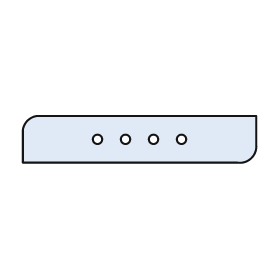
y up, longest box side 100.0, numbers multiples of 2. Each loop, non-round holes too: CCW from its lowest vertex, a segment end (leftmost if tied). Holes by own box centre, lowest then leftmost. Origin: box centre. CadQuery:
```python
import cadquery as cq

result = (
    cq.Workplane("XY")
    .moveTo(-50.0, -10.0)
    .lineTo(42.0, -10.0)
    .threePointArc((48.0, -8.0), (50.0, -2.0))
    .lineTo(50.0, 10.0)
    .lineTo(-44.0, 10.0)
    .threePointArc((-48.0, 8.0), (-50.0, 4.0))
    .close()
    .moveTo(-18.0, 0.0)
    .circle(2.0)
    .moveTo(-6.0, 0.0)
    .circle(2.0)
    .moveTo(6.0, 0.0)
    .circle(2.0)
    .moveTo(18.0, 0.0)
    .circle(2.0)
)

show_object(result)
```